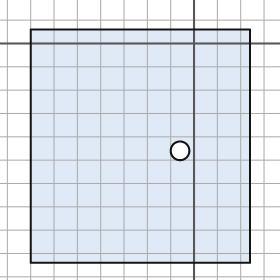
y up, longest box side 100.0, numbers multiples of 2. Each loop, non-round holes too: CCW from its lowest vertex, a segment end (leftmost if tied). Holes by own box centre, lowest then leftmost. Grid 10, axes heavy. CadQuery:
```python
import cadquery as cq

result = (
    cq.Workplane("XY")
    .moveTo(-70.0, -94.0)
    .lineTo(24.0, -94.0)
    .lineTo(24.0, 6.0)
    .lineTo(-70.0, 6.0)
    .close()
    .moveTo(-6.0, -46.0)
    .circle(4.0)
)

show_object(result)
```